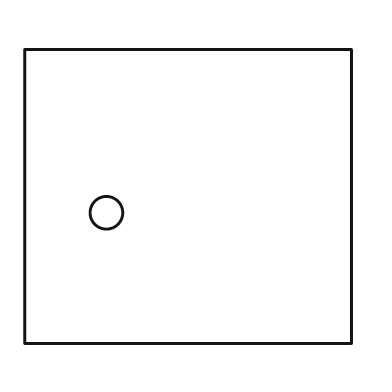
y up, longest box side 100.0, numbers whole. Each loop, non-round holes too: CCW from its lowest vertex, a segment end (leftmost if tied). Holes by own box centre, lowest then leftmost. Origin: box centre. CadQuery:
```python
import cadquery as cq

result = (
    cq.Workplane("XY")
    .moveTo(-50.0, -45.0)
    .lineTo(50.0, -45.0)
    .lineTo(50.0, 45.0)
    .lineTo(-50.0, 45.0)
    .close()
    .moveTo(-25.0, -5.0)
    .circle(5.0)
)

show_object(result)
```